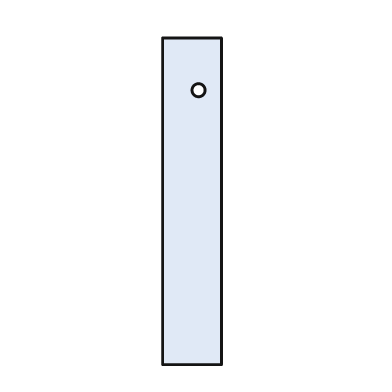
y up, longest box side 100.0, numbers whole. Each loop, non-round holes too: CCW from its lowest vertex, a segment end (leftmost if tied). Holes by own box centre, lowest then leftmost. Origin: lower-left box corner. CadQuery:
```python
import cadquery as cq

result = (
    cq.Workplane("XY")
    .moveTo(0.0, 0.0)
    .lineTo(18.0, 0.0)
    .lineTo(18.0, 100.0)
    .lineTo(0.0, 100.0)
    .close()
    .moveTo(11.0, 84.0)
    .circle(2.0)
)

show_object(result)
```